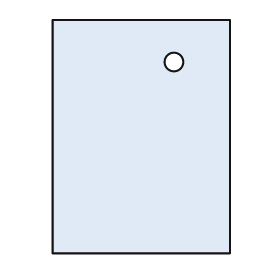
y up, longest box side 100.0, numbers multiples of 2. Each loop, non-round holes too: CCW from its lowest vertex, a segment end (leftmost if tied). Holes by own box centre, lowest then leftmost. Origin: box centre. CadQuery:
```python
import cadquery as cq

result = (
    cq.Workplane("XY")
    .moveTo(-38.0, -50.0)
    .lineTo(38.0, -50.0)
    .lineTo(38.0, 50.0)
    .lineTo(-38.0, 50.0)
    .close()
    .moveTo(14.0, 32.0)
    .circle(4.0)
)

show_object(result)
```